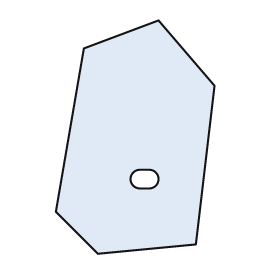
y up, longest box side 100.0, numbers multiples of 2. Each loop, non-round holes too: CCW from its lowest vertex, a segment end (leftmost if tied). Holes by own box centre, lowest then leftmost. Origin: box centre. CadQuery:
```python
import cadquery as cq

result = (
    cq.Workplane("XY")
    .moveTo(-16.0, -50.0)
    .lineTo(26.0, -46.0)
    .lineTo(34.0, 22.0)
    .lineTo(10.0, 50.0)
    .lineTo(-22.0, 38.0)
    .lineTo(-34.0, -32.0)
    .close()
    .moveTo(2.0, -22.0)
    .lineTo(6.0, -22.0)
    .threePointArc((10.0, -18.0), (6.0, -14.0))
    .lineTo(2.0, -14.0)
    .threePointArc((-2.0, -18.0), (2.0, -22.0))
    .close()
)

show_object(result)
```